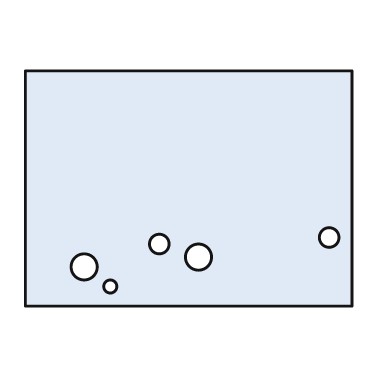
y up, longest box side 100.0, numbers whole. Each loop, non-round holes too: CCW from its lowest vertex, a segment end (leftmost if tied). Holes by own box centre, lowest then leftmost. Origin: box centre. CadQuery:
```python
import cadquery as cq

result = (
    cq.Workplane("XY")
    .moveTo(-50.0, -36.0)
    .lineTo(50.0, -36.0)
    .lineTo(50.0, 36.0)
    .lineTo(-50.0, 36.0)
    .close()
    .moveTo(-24.0, -30.0)
    .circle(2.0)
    .moveTo(-32.0, -24.0)
    .circle(4.0)
    .moveTo(3.0, -21.0)
    .circle(4.0)
    .moveTo(-9.0, -17.0)
    .circle(3.0)
    .moveTo(43.0, -15.0)
    .circle(3.0)
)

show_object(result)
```